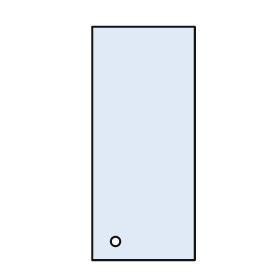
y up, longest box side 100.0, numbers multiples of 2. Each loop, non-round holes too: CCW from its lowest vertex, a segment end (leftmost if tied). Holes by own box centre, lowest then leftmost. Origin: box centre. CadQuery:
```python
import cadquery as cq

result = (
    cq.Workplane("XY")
    .moveTo(-22.0, -50.0)
    .lineTo(22.0, -50.0)
    .lineTo(22.0, 50.0)
    .lineTo(-22.0, 50.0)
    .close()
    .moveTo(-12.0, -42.0)
    .circle(2.0)
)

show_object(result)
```